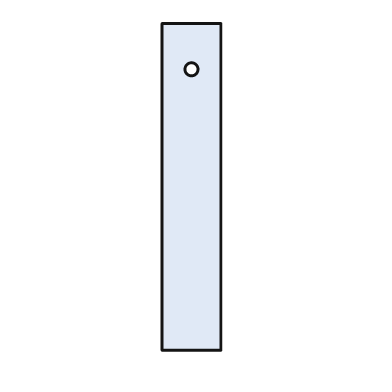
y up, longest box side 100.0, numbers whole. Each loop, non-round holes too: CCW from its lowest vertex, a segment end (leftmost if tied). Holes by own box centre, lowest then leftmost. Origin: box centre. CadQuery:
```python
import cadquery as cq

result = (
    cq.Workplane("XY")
    .moveTo(-9.0, -50.0)
    .lineTo(9.0, -50.0)
    .lineTo(9.0, 50.0)
    .lineTo(-9.0, 50.0)
    .close()
    .moveTo(0.0, 36.0)
    .circle(2.0)
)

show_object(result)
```